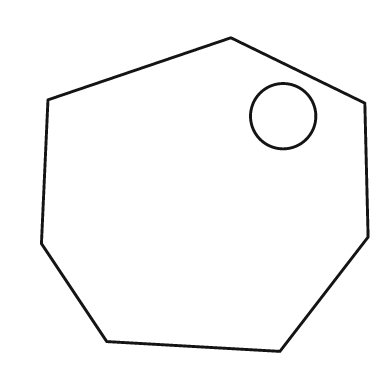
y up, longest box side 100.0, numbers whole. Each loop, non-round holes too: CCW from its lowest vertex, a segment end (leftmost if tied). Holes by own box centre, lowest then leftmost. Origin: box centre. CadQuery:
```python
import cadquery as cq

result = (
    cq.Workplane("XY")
    .moveTo(23.0, -48.0)
    .lineTo(50.0, -13.0)
    .lineTo(49.0, 28.0)
    .lineTo(8.0, 48.0)
    .lineTo(-48.0, 29.0)
    .lineTo(-50.0, -15.0)
    .lineTo(-30.0, -45.0)
    .close()
    .moveTo(24.0, 24.0)
    .circle(10.0)
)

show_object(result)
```